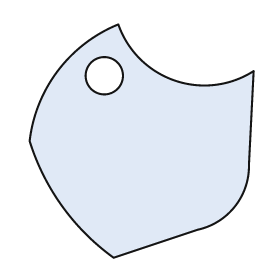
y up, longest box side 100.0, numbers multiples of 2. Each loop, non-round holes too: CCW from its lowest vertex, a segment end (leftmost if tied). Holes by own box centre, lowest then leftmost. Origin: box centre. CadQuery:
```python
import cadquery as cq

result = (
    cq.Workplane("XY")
    .moveTo(-12.0, -50.0)
    .lineTo(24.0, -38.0)
    .threePointArc((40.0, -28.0), (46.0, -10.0))
    .lineTo(48.0, 30.0)
    .threePointArc((14.0, 26.0), (-10.0, 50.0))
    .threePointArc((-36.0, 30.0), (-48.0, 0.0))
    .threePointArc((-34.0, -28.0), (-12.0, -50.0))
    .close()
    .moveTo(-16.0, 28.0)
    .circle(8.0)
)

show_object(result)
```